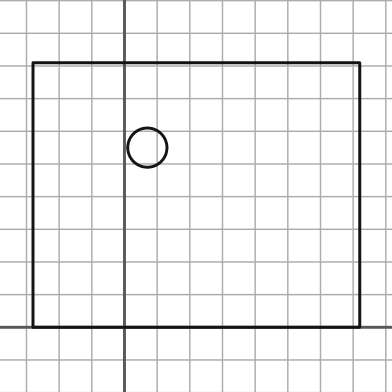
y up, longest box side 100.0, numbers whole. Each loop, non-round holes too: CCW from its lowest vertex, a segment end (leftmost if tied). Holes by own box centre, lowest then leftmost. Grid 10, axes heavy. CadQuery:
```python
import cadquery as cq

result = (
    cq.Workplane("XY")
    .moveTo(-28.0, 0.0)
    .lineTo(72.0, 0.0)
    .lineTo(72.0, 81.0)
    .lineTo(-28.0, 81.0)
    .close()
    .moveTo(7.0, 55.0)
    .circle(6.0)
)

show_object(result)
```